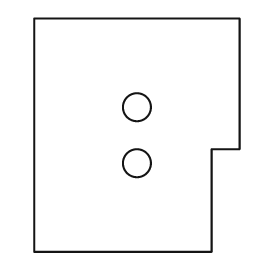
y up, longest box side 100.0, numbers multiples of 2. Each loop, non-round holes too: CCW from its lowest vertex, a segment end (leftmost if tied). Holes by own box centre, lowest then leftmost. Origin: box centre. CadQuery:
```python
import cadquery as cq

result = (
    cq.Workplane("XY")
    .moveTo(-44.0, -50.0)
    .lineTo(32.0, -50.0)
    .lineTo(32.0, -6.0)
    .lineTo(44.0, -6.0)
    .lineTo(44.0, 50.0)
    .lineTo(-44.0, 50.0)
    .close()
    .moveTo(0.0, -12.0)
    .circle(6.0)
    .moveTo(0.0, 12.0)
    .circle(6.0)
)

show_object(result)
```